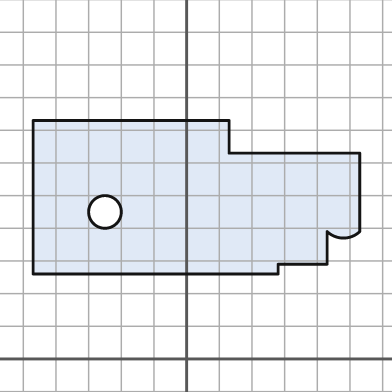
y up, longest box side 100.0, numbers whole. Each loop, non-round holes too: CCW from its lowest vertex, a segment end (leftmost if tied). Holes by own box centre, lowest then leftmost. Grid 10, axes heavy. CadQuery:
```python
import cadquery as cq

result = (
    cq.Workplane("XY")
    .moveTo(-47.0, 26.0)
    .lineTo(28.0, 26.0)
    .lineTo(28.0, 29.0)
    .lineTo(43.0, 29.0)
    .lineTo(43.0, 39.0)
    .threePointArc((48.0, 37.0), (53.0, 39.0))
    .lineTo(53.0, 63.0)
    .lineTo(13.0, 63.0)
    .lineTo(13.0, 73.0)
    .lineTo(-47.0, 73.0)
    .close()
    .moveTo(-25.0, 45.0)
    .circle(5.0)
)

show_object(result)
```